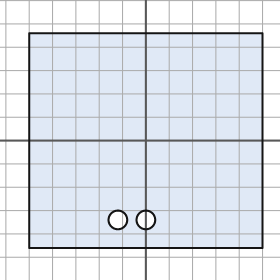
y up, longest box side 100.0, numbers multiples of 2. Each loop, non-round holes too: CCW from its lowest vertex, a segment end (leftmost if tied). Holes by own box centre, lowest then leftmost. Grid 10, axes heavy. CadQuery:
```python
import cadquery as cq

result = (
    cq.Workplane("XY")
    .moveTo(-50.0, -46.0)
    .lineTo(50.0, -46.0)
    .lineTo(50.0, 46.0)
    .lineTo(-50.0, 46.0)
    .close()
    .moveTo(-12.0, -34.0)
    .circle(4.0)
    .moveTo(0.0, -34.0)
    .circle(4.0)
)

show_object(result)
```